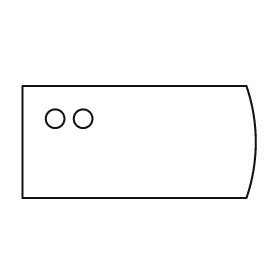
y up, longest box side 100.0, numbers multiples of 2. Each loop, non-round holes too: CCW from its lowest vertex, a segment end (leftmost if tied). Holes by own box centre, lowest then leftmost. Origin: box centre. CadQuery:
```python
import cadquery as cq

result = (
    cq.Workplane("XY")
    .moveTo(-50.0, -24.0)
    .lineTo(46.0, -24.0)
    .threePointArc((50.0, 0.0), (46.0, 24.0))
    .lineTo(-50.0, 24.0)
    .close()
    .moveTo(-36.0, 10.0)
    .circle(4.0)
    .moveTo(-24.0, 10.0)
    .circle(4.0)
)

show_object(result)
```